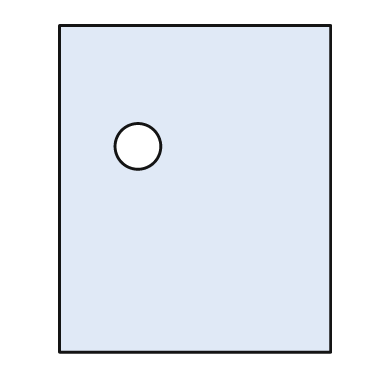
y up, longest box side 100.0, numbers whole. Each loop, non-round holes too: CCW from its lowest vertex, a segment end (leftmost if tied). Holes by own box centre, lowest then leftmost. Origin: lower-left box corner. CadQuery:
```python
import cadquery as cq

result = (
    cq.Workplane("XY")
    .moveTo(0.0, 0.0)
    .lineTo(83.0, 0.0)
    .lineTo(83.0, 100.0)
    .lineTo(0.0, 100.0)
    .close()
    .moveTo(24.0, 63.0)
    .circle(7.0)
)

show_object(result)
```